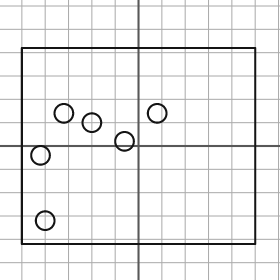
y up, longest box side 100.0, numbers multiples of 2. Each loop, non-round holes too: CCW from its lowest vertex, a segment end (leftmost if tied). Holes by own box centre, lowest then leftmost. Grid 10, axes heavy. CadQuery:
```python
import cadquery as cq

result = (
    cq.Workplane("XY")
    .moveTo(-50.0, -42.0)
    .lineTo(50.0, -42.0)
    .lineTo(50.0, 42.0)
    .lineTo(-50.0, 42.0)
    .close()
    .moveTo(-40.0, -32.0)
    .circle(4.0)
    .moveTo(-42.0, -4.0)
    .circle(4.0)
    .moveTo(-6.0, 2.0)
    .circle(4.0)
    .moveTo(-20.0, 10.0)
    .circle(4.0)
    .moveTo(-32.0, 14.0)
    .circle(4.0)
    .moveTo(8.0, 14.0)
    .circle(4.0)
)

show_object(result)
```